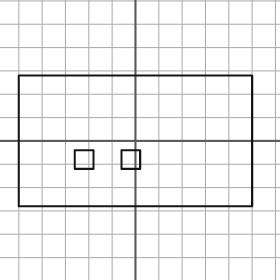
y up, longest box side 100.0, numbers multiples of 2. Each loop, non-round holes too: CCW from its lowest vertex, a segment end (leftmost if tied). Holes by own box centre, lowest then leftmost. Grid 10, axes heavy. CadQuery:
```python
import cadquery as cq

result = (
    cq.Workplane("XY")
    .moveTo(-50.0, -28.0)
    .lineTo(50.0, -28.0)
    .lineTo(50.0, 28.0)
    .lineTo(-50.0, 28.0)
    .close()
    .moveTo(-26.0, -12.0)
    .lineTo(-18.0, -12.0)
    .lineTo(-18.0, -4.0)
    .lineTo(-26.0, -4.0)
    .close()
    .moveTo(-6.0, -12.0)
    .lineTo(2.0, -12.0)
    .lineTo(2.0, -4.0)
    .lineTo(-6.0, -4.0)
    .close()
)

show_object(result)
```